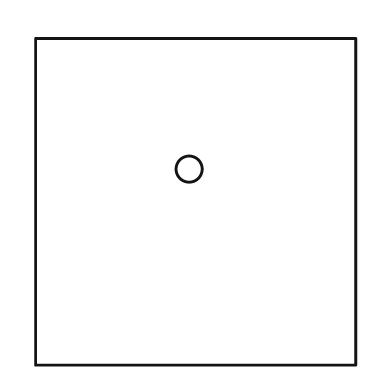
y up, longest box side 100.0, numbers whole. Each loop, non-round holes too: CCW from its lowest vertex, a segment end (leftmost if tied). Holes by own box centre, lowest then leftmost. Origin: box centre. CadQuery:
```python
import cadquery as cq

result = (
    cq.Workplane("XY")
    .moveTo(-49.0, -50.0)
    .lineTo(49.0, -50.0)
    .lineTo(49.0, 50.0)
    .lineTo(-49.0, 50.0)
    .close()
    .moveTo(-2.0, 10.0)
    .circle(4.0)
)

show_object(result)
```